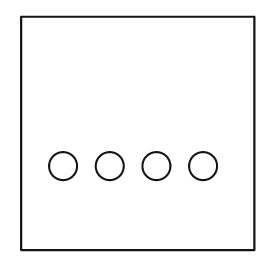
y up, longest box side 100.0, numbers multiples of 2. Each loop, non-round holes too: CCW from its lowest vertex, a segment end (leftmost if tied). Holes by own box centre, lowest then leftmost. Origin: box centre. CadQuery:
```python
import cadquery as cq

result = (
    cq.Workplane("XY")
    .moveTo(-50.0, -50.0)
    .lineTo(50.0, -50.0)
    .lineTo(50.0, 50.0)
    .lineTo(-50.0, 50.0)
    .close()
    .moveTo(-32.0, -14.0)
    .circle(6.0)
    .moveTo(-12.0, -14.0)
    .circle(6.0)
    .moveTo(8.0, -14.0)
    .circle(6.0)
    .moveTo(28.0, -14.0)
    .circle(6.0)
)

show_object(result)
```